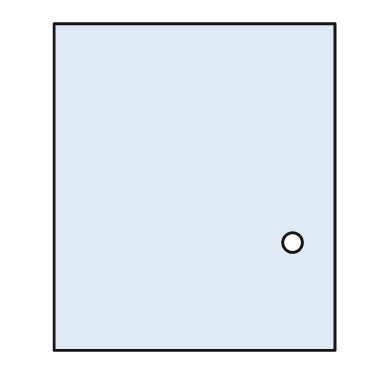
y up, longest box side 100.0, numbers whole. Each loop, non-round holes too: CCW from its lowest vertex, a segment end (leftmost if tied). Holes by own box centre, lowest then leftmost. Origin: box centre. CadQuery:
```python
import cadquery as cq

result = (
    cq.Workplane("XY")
    .moveTo(-43.0, -50.0)
    .lineTo(43.0, -50.0)
    .lineTo(43.0, 50.0)
    .lineTo(-43.0, 50.0)
    .close()
    .moveTo(30.0, -17.0)
    .circle(3.0)
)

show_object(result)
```